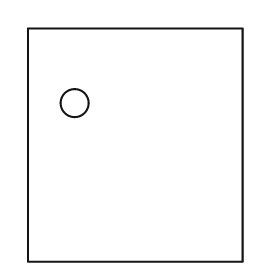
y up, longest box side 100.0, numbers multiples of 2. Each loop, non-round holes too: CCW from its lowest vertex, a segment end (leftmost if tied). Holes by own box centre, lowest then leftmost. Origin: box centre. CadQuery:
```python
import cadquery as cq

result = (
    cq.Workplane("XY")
    .moveTo(-46.0, -50.0)
    .lineTo(46.0, -50.0)
    .lineTo(46.0, 50.0)
    .lineTo(-46.0, 50.0)
    .close()
    .moveTo(-26.0, 18.0)
    .circle(6.0)
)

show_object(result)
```